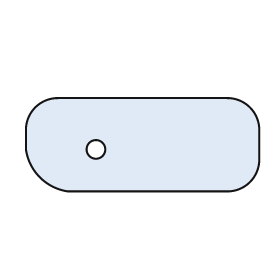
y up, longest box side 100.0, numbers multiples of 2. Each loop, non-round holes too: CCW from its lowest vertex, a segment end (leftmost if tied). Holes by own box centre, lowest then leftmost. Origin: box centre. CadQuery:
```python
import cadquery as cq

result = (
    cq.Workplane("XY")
    .moveTo(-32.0, -20.0)
    .lineTo(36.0, -20.0)
    .threePointArc((46.0, -16.0), (50.0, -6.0))
    .lineTo(50.0, 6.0)
    .threePointArc((46.0, 16.0), (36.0, 20.0))
    .lineTo(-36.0, 20.0)
    .threePointArc((-46.0, 16.0), (-50.0, 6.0))
    .lineTo(-50.0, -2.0)
    .threePointArc((-44.0, -14.0), (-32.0, -20.0))
    .close()
    .moveTo(-20.0, -2.0)
    .circle(4.0)
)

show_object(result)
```